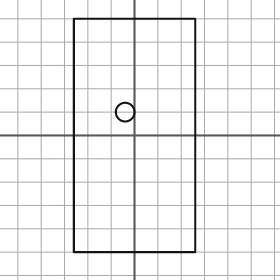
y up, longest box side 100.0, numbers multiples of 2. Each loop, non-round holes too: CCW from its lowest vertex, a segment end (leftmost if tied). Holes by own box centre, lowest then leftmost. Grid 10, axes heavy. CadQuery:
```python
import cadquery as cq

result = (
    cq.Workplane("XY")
    .moveTo(-26.0, -50.0)
    .lineTo(26.0, -50.0)
    .lineTo(26.0, 50.0)
    .lineTo(-26.0, 50.0)
    .close()
    .moveTo(-4.0, 10.0)
    .circle(4.0)
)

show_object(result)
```